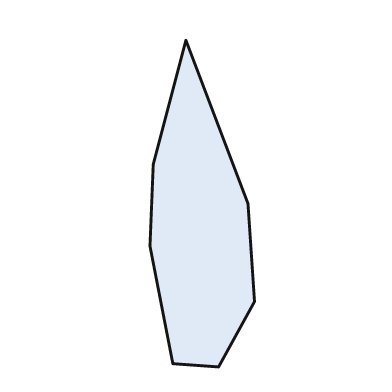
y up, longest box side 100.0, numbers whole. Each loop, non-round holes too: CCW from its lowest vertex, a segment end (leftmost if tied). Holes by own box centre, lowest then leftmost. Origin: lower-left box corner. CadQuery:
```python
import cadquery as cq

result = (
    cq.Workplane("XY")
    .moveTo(21.0, 0.0)
    .lineTo(32.0, 20.0)
    .lineTo(30.0, 50.0)
    .lineTo(11.0, 100.0)
    .lineTo(1.0, 62.0)
    .lineTo(0.0, 37.0)
    .lineTo(7.0, 1.0)
    .close()
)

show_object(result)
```